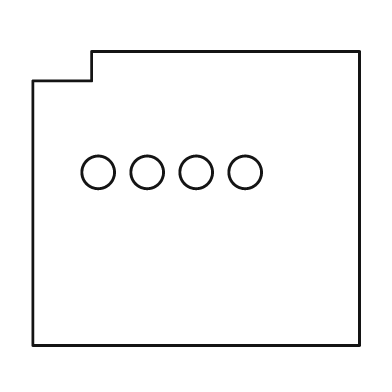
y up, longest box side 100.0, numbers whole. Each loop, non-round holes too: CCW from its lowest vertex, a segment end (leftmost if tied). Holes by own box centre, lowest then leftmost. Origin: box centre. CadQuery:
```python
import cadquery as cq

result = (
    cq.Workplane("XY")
    .moveTo(-50.0, -45.0)
    .lineTo(50.0, -45.0)
    .lineTo(50.0, 45.0)
    .lineTo(-32.0, 45.0)
    .lineTo(-32.0, 36.0)
    .lineTo(-50.0, 36.0)
    .close()
    .moveTo(-30.0, 8.0)
    .circle(5.0)
    .moveTo(-15.0, 8.0)
    .circle(5.0)
    .moveTo(0.0, 8.0)
    .circle(5.0)
    .moveTo(15.0, 8.0)
    .circle(5.0)
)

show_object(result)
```